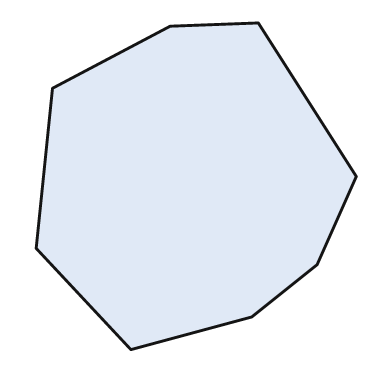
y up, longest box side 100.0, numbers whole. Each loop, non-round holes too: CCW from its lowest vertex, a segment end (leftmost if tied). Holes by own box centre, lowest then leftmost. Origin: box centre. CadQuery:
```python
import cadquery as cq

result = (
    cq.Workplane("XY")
    .moveTo(-20.0, -50.0)
    .lineTo(17.0, -40.0)
    .lineTo(37.0, -24.0)
    .lineTo(49.0, 3.0)
    .lineTo(19.0, 50.0)
    .lineTo(-8.0, 49.0)
    .lineTo(-44.0, 30.0)
    .lineTo(-49.0, -19.0)
    .close()
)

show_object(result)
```